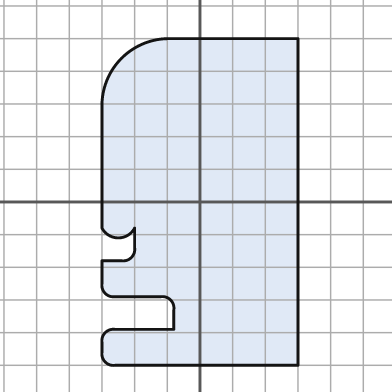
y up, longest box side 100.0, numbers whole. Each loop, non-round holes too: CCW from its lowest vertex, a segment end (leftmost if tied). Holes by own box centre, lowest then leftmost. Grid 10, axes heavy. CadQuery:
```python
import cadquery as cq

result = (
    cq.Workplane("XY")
    .moveTo(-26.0, -50.0)
    .lineTo(30.0, -50.0)
    .lineTo(30.0, 50.0)
    .lineTo(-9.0, 50.0)
    .threePointArc((-24.0, 44.0), (-30.0, 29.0))
    .lineTo(-30.0, -8.0)
    .threePointArc((-25.0, -11.0), (-20.0, -8.0))
    .lineTo(-20.0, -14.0)
    .threePointArc((-21.0, -17.0), (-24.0, -18.0))
    .lineTo(-30.0, -18.0)
    .lineTo(-30.0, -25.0)
    .threePointArc((-29.0, -28.0), (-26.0, -29.0))
    .lineTo(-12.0, -29.0)
    .threePointArc((-9.0, -30.0), (-8.0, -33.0))
    .lineTo(-8.0, -39.0)
    .lineTo(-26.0, -39.0)
    .threePointArc((-29.0, -40.0), (-30.0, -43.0))
    .lineTo(-30.0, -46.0)
    .threePointArc((-29.0, -49.0), (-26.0, -50.0))
    .close()
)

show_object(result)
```